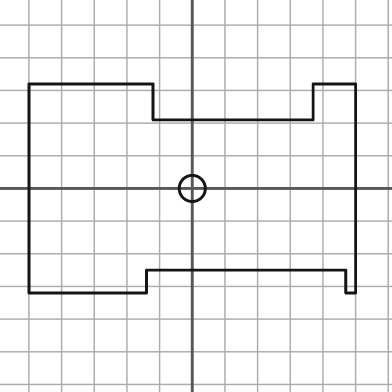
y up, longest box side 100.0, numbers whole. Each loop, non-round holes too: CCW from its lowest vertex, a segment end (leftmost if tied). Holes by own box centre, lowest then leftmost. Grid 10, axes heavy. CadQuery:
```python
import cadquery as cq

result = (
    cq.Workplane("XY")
    .moveTo(-50.0, -32.0)
    .lineTo(-14.0, -32.0)
    .lineTo(-14.0, -25.0)
    .lineTo(47.0, -25.0)
    .lineTo(47.0, -32.0)
    .lineTo(50.0, -32.0)
    .lineTo(50.0, 32.0)
    .lineTo(37.0, 32.0)
    .lineTo(37.0, 21.0)
    .lineTo(-12.0, 21.0)
    .lineTo(-12.0, 32.0)
    .lineTo(-50.0, 32.0)
    .close()
    .moveTo(0.0, 0.0)
    .circle(4.0)
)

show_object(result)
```